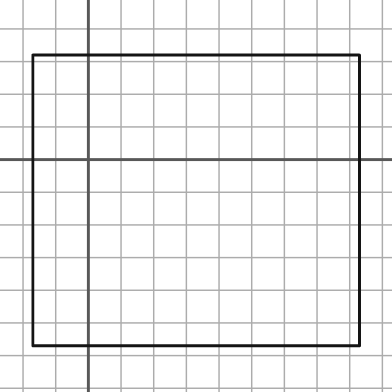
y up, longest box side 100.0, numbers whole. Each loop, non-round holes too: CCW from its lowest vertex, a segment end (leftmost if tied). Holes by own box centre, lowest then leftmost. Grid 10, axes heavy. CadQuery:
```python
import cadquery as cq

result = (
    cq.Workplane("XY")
    .moveTo(-17.0, -57.0)
    .lineTo(83.0, -57.0)
    .lineTo(83.0, 32.0)
    .lineTo(-17.0, 32.0)
    .close()
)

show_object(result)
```